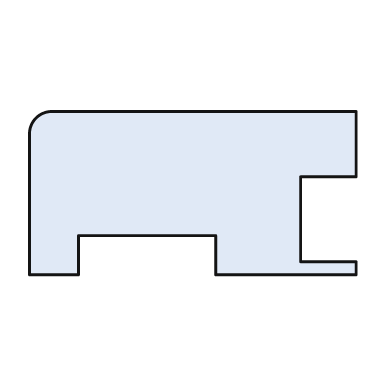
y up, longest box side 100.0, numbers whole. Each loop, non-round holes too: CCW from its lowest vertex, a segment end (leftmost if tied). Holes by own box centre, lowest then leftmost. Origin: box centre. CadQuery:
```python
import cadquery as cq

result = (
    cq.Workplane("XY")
    .moveTo(-50.0, -25.0)
    .lineTo(-35.0, -25.0)
    .lineTo(-35.0, -13.0)
    .lineTo(7.0, -13.0)
    .lineTo(7.0, -25.0)
    .lineTo(50.0, -25.0)
    .lineTo(50.0, -21.0)
    .lineTo(33.0, -21.0)
    .lineTo(33.0, 5.0)
    .lineTo(50.0, 5.0)
    .lineTo(50.0, 25.0)
    .lineTo(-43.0, 25.0)
    .threePointArc((-48.0, 23.0), (-50.0, 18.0))
    .close()
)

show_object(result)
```